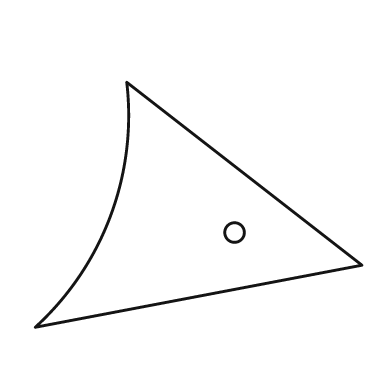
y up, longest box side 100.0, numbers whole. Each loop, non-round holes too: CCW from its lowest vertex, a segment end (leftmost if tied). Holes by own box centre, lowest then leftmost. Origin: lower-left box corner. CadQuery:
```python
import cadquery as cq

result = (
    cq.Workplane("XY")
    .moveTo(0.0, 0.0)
    .lineTo(100.0, 19.0)
    .lineTo(28.0, 75.0)
    .threePointArc((23.0, 34.0), (0.0, 0.0))
    .close()
    .moveTo(61.0, 29.0)
    .circle(3.0)
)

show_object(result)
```